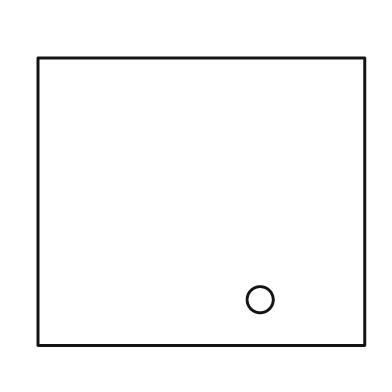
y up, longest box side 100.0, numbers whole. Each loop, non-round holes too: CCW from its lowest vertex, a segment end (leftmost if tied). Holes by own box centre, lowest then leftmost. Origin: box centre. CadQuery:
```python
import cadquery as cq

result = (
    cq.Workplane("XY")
    .moveTo(-50.0, -44.0)
    .lineTo(50.0, -44.0)
    .lineTo(50.0, 44.0)
    .lineTo(-50.0, 44.0)
    .close()
    .moveTo(18.0, -30.0)
    .circle(4.0)
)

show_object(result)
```